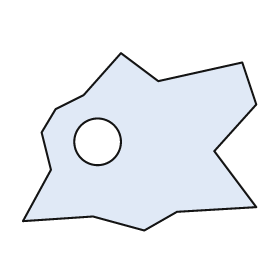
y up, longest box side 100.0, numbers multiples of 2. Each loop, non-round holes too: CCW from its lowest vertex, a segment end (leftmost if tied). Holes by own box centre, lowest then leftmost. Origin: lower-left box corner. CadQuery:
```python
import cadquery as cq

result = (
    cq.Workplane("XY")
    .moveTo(52.0, 0.0)
    .lineTo(66.0, 8.0)
    .lineTo(100.0, 10.0)
    .lineTo(82.0, 34.0)
    .lineTo(100.0, 54.0)
    .lineTo(94.0, 72.0)
    .lineTo(58.0, 64.0)
    .lineTo(42.0, 76.0)
    .lineTo(26.0, 58.0)
    .lineTo(14.0, 52.0)
    .lineTo(8.0, 42.0)
    .lineTo(12.0, 26.0)
    .lineTo(0.0, 4.0)
    .lineTo(30.0, 6.0)
    .close()
    .moveTo(32.0, 38.0)
    .circle(10.0)
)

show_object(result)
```